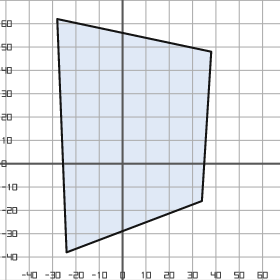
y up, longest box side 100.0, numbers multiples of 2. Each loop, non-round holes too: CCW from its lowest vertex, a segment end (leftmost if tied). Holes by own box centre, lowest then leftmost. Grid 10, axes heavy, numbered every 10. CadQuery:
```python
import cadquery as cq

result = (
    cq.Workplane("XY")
    .moveTo(-24.0, -38.0)
    .lineTo(34.0, -16.0)
    .lineTo(38.0, 48.0)
    .lineTo(-28.0, 62.0)
    .close()
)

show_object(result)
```